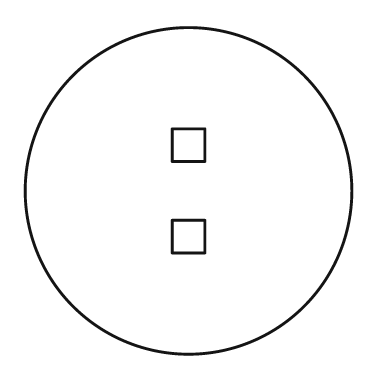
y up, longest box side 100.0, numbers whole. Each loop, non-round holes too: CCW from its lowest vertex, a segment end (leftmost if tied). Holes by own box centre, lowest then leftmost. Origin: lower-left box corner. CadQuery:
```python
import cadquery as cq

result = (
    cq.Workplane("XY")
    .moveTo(50.0, 50.0)
    .circle(50.0)
    .moveTo(45.0, 31.0)
    .lineTo(55.0, 31.0)
    .lineTo(55.0, 41.0)
    .lineTo(45.0, 41.0)
    .close()
    .moveTo(45.0, 59.0)
    .lineTo(55.0, 59.0)
    .lineTo(55.0, 69.0)
    .lineTo(45.0, 69.0)
    .close()
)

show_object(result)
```